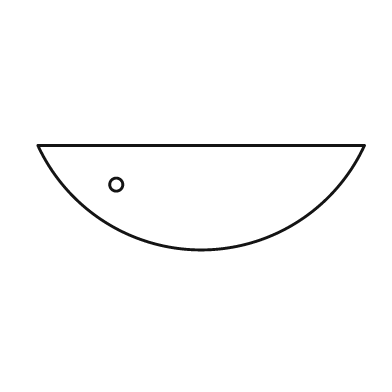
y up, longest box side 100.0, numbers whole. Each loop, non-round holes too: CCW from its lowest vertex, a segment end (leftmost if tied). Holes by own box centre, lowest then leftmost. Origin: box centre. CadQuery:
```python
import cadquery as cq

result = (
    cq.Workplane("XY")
    .moveTo(-50.0, 16.0)
    .threePointArc((0.0, -16.0), (50.0, 16.0))
    .close()
    .moveTo(-26.0, 4.0)
    .circle(2.0)
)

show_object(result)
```